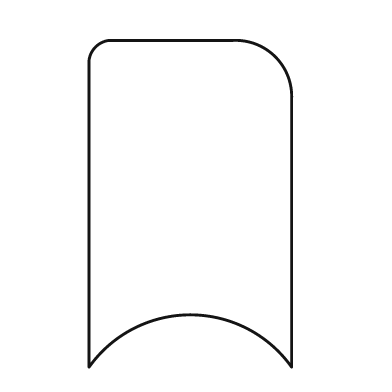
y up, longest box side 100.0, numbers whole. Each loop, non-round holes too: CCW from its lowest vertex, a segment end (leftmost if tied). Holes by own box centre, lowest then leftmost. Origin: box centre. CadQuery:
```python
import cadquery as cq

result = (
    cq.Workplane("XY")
    .moveTo(-31.0, -50.0)
    .threePointArc((0.0, -34.0), (31.0, -50.0))
    .lineTo(31.0, 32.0)
    .threePointArc((26.0, 45.0), (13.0, 50.0))
    .lineTo(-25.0, 50.0)
    .threePointArc((-29.0, 48.0), (-31.0, 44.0))
    .close()
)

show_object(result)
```